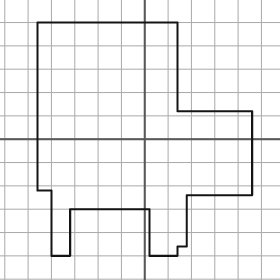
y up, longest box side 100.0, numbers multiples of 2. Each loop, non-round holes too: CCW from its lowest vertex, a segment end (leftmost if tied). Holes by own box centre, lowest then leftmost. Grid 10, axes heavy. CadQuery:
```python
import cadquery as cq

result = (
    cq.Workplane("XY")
    .moveTo(-40.0, -50.0)
    .lineTo(-32.0, -50.0)
    .lineTo(-32.0, -30.0)
    .lineTo(2.0, -30.0)
    .lineTo(2.0, -50.0)
    .lineTo(14.0, -50.0)
    .lineTo(14.0, -46.0)
    .lineTo(18.0, -46.0)
    .lineTo(18.0, -24.0)
    .lineTo(46.0, -24.0)
    .lineTo(46.0, 12.0)
    .lineTo(14.0, 12.0)
    .lineTo(14.0, 50.0)
    .lineTo(-46.0, 50.0)
    .lineTo(-46.0, -22.0)
    .lineTo(-40.0, -22.0)
    .close()
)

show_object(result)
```